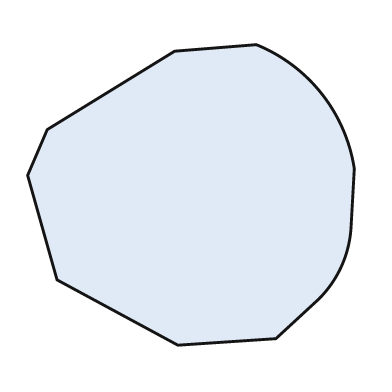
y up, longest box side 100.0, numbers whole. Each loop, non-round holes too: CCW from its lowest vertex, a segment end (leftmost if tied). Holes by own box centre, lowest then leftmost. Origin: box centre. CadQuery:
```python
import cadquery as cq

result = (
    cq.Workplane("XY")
    .moveTo(-4.0, -46.0)
    .lineTo(26.0, -44.0)
    .lineTo(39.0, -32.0)
    .threePointArc((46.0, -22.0), (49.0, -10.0))
    .lineTo(50.0, 8.0)
    .threePointArc((40.0, 31.0), (20.0, 46.0))
    .lineTo(-5.0, 44.0)
    .lineTo(-44.0, 20.0)
    .lineTo(-50.0, 6.0)
    .lineTo(-41.0, -26.0)
    .close()
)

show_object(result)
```